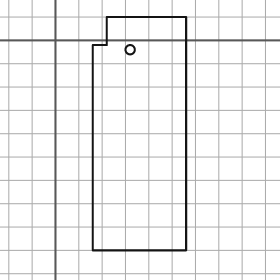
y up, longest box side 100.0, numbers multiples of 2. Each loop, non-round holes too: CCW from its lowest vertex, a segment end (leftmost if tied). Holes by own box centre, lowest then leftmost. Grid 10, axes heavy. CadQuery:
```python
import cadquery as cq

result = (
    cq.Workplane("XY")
    .moveTo(16.0, -90.0)
    .lineTo(56.0, -90.0)
    .lineTo(56.0, 10.0)
    .lineTo(22.0, 10.0)
    .lineTo(22.0, -2.0)
    .lineTo(16.0, -2.0)
    .close()
    .moveTo(32.0, -4.0)
    .circle(2.0)
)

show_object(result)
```